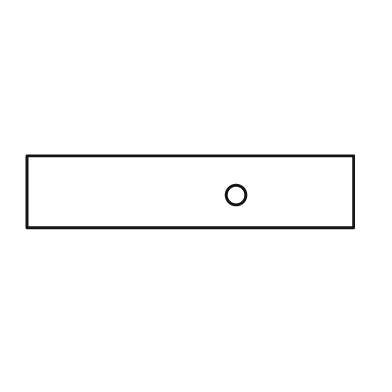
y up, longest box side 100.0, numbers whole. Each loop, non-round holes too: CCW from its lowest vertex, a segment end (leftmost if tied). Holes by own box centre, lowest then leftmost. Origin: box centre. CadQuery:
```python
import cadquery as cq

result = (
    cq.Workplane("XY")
    .moveTo(-50.0, -11.0)
    .lineTo(50.0, -11.0)
    .lineTo(50.0, 11.0)
    .lineTo(-50.0, 11.0)
    .close()
    .moveTo(14.0, -1.0)
    .circle(3.0)
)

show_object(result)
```